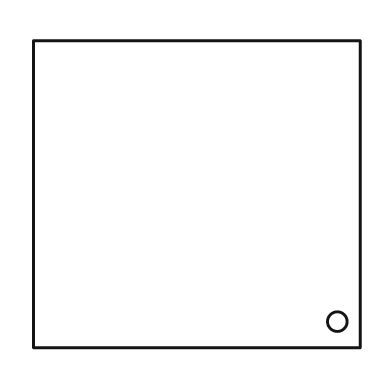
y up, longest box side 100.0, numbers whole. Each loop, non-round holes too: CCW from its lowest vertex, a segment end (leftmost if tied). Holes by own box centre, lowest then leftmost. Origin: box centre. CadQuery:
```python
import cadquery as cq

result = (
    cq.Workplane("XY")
    .moveTo(-50.0, -47.0)
    .lineTo(50.0, -47.0)
    .lineTo(50.0, 47.0)
    .lineTo(-50.0, 47.0)
    .close()
    .moveTo(43.0, -39.0)
    .circle(3.0)
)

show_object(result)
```